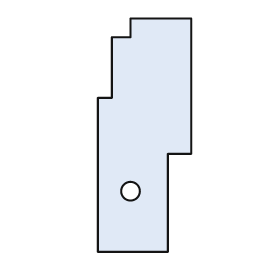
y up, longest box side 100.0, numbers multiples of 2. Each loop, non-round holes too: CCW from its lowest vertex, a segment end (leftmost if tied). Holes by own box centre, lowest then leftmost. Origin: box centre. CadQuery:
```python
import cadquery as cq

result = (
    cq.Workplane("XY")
    .moveTo(-20.0, -50.0)
    .lineTo(10.0, -50.0)
    .lineTo(10.0, -8.0)
    .lineTo(20.0, -8.0)
    .lineTo(20.0, 50.0)
    .lineTo(-6.0, 50.0)
    .lineTo(-6.0, 42.0)
    .lineTo(-14.0, 42.0)
    .lineTo(-14.0, 16.0)
    .lineTo(-20.0, 16.0)
    .close()
    .moveTo(-6.0, -24.0)
    .circle(4.0)
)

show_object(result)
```